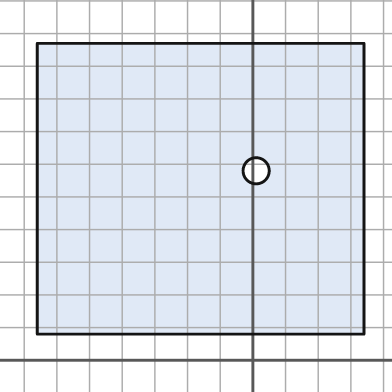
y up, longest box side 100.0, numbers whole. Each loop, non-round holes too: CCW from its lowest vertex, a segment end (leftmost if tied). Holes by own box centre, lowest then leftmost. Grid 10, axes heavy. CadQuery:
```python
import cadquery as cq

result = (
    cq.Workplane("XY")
    .moveTo(-66.0, 8.0)
    .lineTo(34.0, 8.0)
    .lineTo(34.0, 97.0)
    .lineTo(-66.0, 97.0)
    .close()
    .moveTo(1.0, 58.0)
    .circle(4.0)
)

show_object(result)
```